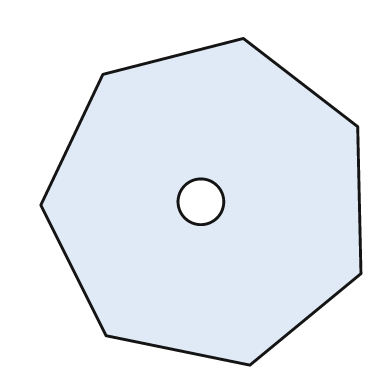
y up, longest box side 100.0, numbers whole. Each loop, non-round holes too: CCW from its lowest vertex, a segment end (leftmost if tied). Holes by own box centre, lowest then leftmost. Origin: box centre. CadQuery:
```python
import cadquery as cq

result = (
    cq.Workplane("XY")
    .moveTo(15.0, -50.0)
    .lineTo(49.0, -22.0)
    .lineTo(48.0, 23.0)
    .lineTo(13.0, 50.0)
    .lineTo(-30.0, 39.0)
    .lineTo(-49.0, -1.0)
    .lineTo(-29.0, -41.0)
    .close()
    .moveTo(0.0, 0.0)
    .circle(7.0)
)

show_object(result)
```